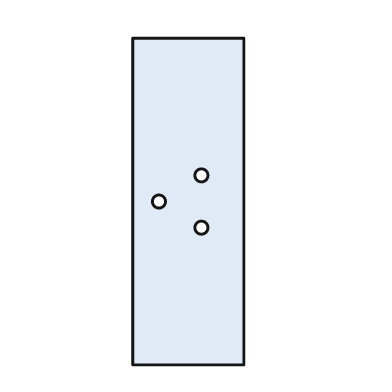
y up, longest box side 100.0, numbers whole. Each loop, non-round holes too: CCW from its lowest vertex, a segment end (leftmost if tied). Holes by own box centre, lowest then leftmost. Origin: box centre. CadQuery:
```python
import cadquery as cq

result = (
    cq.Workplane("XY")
    .moveTo(-17.0, -50.0)
    .lineTo(17.0, -50.0)
    .lineTo(17.0, 50.0)
    .lineTo(-17.0, 50.0)
    .close()
    .moveTo(4.0, -8.0)
    .circle(2.0)
    .moveTo(-9.0, 0.0)
    .circle(2.0)
    .moveTo(4.0, 8.0)
    .circle(2.0)
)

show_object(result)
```